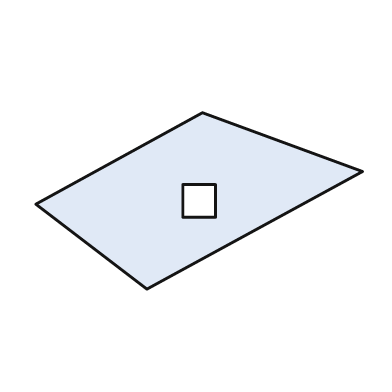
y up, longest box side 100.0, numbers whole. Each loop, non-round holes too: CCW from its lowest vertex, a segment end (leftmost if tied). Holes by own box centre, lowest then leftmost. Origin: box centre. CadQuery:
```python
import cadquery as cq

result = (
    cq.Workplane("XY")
    .moveTo(-16.0, -27.0)
    .lineTo(50.0, 9.0)
    .lineTo(1.0, 27.0)
    .lineTo(-50.0, -1.0)
    .close()
    .moveTo(-5.0, -5.0)
    .lineTo(5.0, -5.0)
    .lineTo(5.0, 5.0)
    .lineTo(-5.0, 5.0)
    .close()
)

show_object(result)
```